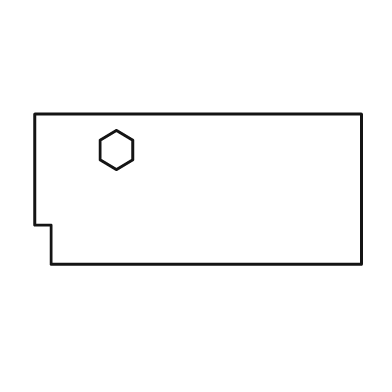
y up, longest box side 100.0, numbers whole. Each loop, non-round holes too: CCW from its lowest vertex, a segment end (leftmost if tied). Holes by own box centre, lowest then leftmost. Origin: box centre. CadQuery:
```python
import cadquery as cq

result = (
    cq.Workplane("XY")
    .moveTo(-45.0, -23.0)
    .lineTo(50.0, -23.0)
    .lineTo(50.0, 23.0)
    .lineTo(-50.0, 23.0)
    .lineTo(-50.0, -11.0)
    .lineTo(-45.0, -11.0)
    .close()
    .moveTo(-25.0, 6.0)
    .lineTo(-20.0, 9.0)
    .lineTo(-20.0, 15.0)
    .lineTo(-25.0, 18.0)
    .lineTo(-30.0, 15.0)
    .lineTo(-30.0, 9.0)
    .close()
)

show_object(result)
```